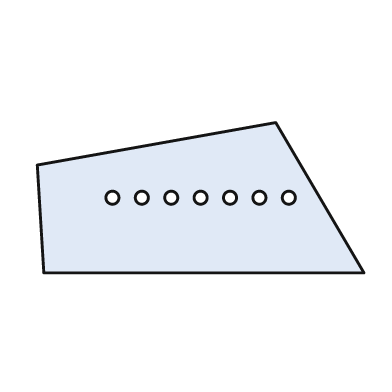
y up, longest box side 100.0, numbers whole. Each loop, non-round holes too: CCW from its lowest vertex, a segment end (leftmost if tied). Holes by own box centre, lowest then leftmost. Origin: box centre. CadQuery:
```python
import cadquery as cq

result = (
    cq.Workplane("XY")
    .moveTo(-48.0, -23.0)
    .lineTo(50.0, -23.0)
    .lineTo(23.0, 23.0)
    .lineTo(-50.0, 10.0)
    .close()
    .moveTo(-27.0, 0.0)
    .circle(2.0)
    .moveTo(-18.0, 0.0)
    .circle(2.0)
    .moveTo(-9.0, 0.0)
    .circle(2.0)
    .moveTo(0.0, 0.0)
    .circle(2.0)
    .moveTo(9.0, 0.0)
    .circle(2.0)
    .moveTo(18.0, 0.0)
    .circle(2.0)
    .moveTo(27.0, 0.0)
    .circle(2.0)
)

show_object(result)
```